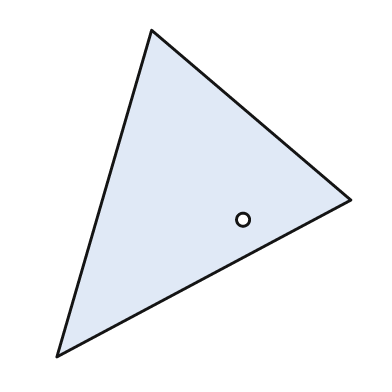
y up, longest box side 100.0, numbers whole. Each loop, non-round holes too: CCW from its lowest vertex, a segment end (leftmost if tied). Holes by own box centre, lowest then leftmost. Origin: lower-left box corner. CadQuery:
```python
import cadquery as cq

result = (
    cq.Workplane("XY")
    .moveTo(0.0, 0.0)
    .lineTo(90.0, 48.0)
    .lineTo(29.0, 100.0)
    .close()
    .moveTo(57.0, 42.0)
    .circle(2.0)
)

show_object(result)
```